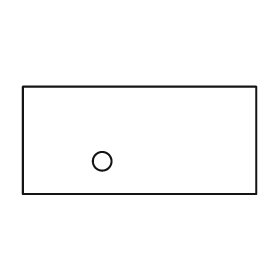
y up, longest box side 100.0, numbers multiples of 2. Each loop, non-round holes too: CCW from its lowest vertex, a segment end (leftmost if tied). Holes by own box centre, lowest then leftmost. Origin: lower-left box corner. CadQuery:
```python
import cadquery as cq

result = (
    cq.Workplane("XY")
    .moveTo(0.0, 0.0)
    .lineTo(100.0, 0.0)
    .lineTo(100.0, 46.0)
    .lineTo(0.0, 46.0)
    .close()
    .moveTo(34.0, 14.0)
    .circle(4.0)
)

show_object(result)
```